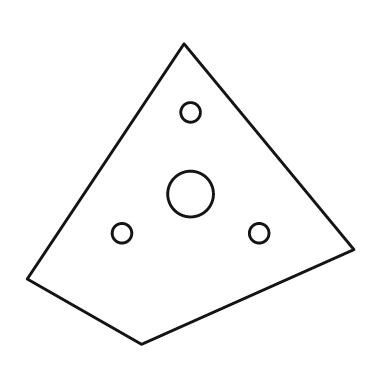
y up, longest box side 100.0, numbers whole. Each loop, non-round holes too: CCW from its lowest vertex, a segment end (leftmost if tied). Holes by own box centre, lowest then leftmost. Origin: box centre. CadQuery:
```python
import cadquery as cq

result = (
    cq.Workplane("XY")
    .moveTo(-15.0, -46.0)
    .lineTo(50.0, -17.0)
    .lineTo(-2.0, 46.0)
    .lineTo(-50.0, -26.0)
    .close()
    .moveTo(-21.0, -12.0)
    .circle(3.0)
    .moveTo(21.0, -12.0)
    .circle(3.0)
    .moveTo(0.0, 0.0)
    .circle(7.0)
    .moveTo(0.0, 25.0)
    .circle(3.0)
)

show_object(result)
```